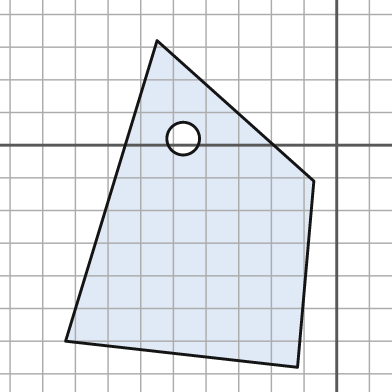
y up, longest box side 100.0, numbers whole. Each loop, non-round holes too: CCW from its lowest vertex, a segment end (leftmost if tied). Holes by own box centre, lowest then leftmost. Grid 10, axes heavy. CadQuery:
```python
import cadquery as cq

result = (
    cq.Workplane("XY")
    .moveTo(-12.0, -68.0)
    .lineTo(-7.0, -11.0)
    .lineTo(-55.0, 32.0)
    .lineTo(-83.0, -60.0)
    .close()
    .moveTo(-47.0, 2.0)
    .circle(5.0)
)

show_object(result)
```